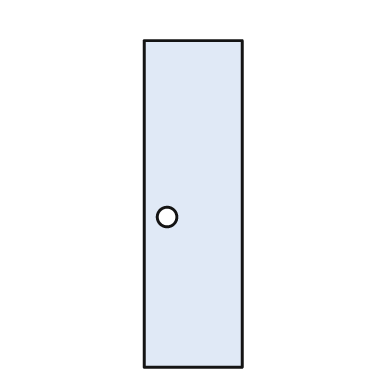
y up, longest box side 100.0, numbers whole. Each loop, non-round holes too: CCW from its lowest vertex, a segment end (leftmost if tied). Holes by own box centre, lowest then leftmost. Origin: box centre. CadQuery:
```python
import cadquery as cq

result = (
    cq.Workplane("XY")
    .moveTo(-15.0, -50.0)
    .lineTo(15.0, -50.0)
    .lineTo(15.0, 50.0)
    .lineTo(-15.0, 50.0)
    .close()
    .moveTo(-8.0, -4.0)
    .circle(3.0)
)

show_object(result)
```